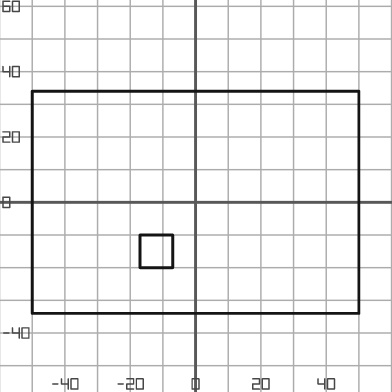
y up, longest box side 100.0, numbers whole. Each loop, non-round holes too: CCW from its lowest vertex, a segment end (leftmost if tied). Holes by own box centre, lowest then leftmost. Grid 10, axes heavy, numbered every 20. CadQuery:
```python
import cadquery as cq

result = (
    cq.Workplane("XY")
    .moveTo(-50.0, -34.0)
    .lineTo(50.0, -34.0)
    .lineTo(50.0, 34.0)
    .lineTo(-50.0, 34.0)
    .close()
    .moveTo(-17.0, -20.0)
    .lineTo(-7.0, -20.0)
    .lineTo(-7.0, -10.0)
    .lineTo(-17.0, -10.0)
    .close()
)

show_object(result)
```